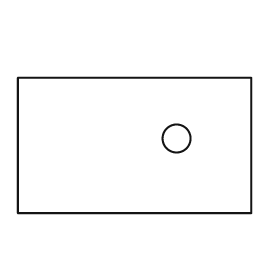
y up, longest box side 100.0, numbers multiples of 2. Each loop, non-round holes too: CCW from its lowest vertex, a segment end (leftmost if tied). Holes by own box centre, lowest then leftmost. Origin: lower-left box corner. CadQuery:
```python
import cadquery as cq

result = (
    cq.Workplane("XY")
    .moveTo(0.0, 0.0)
    .lineTo(100.0, 0.0)
    .lineTo(100.0, 58.0)
    .lineTo(0.0, 58.0)
    .close()
    .moveTo(68.0, 32.0)
    .circle(6.0)
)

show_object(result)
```